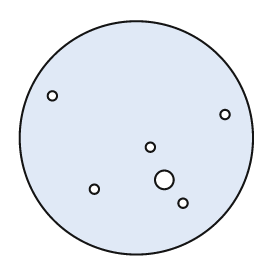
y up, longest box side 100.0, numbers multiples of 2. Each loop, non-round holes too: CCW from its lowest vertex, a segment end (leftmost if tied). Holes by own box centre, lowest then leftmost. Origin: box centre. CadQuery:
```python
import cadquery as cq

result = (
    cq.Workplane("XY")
    .moveTo(0.0, 0.0)
    .circle(50.0)
    .moveTo(20.0, -28.0)
    .circle(2.0)
    .moveTo(-18.0, -22.0)
    .circle(2.0)
    .moveTo(12.0, -18.0)
    .circle(4.0)
    .moveTo(6.0, -4.0)
    .circle(2.0)
    .moveTo(38.0, 10.0)
    .circle(2.0)
    .moveTo(-36.0, 18.0)
    .circle(2.0)
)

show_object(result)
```